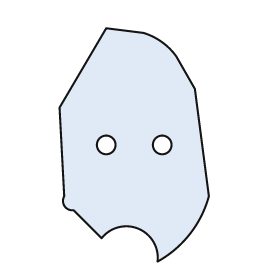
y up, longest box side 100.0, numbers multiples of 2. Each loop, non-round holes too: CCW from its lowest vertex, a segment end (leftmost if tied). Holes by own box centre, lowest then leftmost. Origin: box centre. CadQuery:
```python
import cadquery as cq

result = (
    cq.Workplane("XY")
    .moveTo(10.0, -50.0)
    .threePointArc((24.0, -38.0), (32.0, -22.0))
    .lineTo(26.0, 24.0)
    .lineTo(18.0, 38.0)
    .threePointArc((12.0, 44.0), (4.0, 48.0))
    .lineTo(-12.0, 50.0)
    .lineTo(-32.0, 16.0)
    .lineTo(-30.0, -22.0)
    .threePointArc((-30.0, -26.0), (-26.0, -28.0))
    .lineTo(-14.0, -40.0)
    .threePointArc((2.0, -36.0), (10.0, -50.0))
    .close()
    .moveTo(-12.0, 0.0)
    .circle(4.0)
    .moveTo(12.0, 0.0)
    .circle(4.0)
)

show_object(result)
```